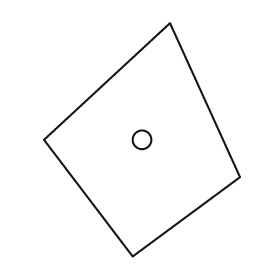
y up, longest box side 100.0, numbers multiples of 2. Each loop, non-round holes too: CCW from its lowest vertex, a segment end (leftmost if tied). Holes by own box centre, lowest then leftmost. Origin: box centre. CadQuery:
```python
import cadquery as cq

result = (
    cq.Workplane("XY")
    .moveTo(-4.0, -50.0)
    .lineTo(42.0, -16.0)
    .lineTo(12.0, 50.0)
    .lineTo(-42.0, 0.0)
    .close()
    .moveTo(0.0, 0.0)
    .circle(4.0)
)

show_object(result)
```